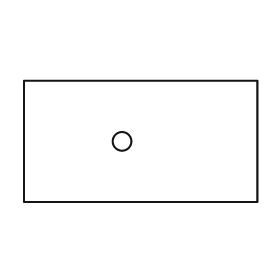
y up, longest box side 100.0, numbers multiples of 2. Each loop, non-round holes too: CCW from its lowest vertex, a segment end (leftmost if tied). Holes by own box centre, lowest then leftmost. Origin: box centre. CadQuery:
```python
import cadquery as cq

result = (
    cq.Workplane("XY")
    .moveTo(-50.0, -26.0)
    .lineTo(50.0, -26.0)
    .lineTo(50.0, 26.0)
    .lineTo(-50.0, 26.0)
    .close()
    .moveTo(-8.0, 0.0)
    .circle(4.0)
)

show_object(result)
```